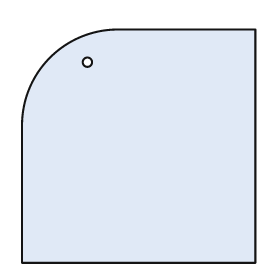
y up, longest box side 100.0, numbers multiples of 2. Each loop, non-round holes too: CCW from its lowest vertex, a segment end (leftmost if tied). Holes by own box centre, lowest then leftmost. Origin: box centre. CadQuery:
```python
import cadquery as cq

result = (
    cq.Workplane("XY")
    .moveTo(-50.0, -50.0)
    .lineTo(50.0, -50.0)
    .lineTo(50.0, 50.0)
    .lineTo(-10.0, 50.0)
    .threePointArc((-38.0, 38.0), (-50.0, 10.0))
    .close()
    .moveTo(-22.0, 36.0)
    .circle(2.0)
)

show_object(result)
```